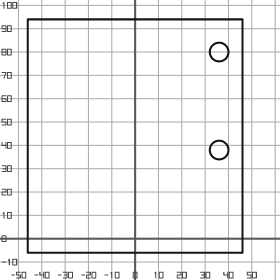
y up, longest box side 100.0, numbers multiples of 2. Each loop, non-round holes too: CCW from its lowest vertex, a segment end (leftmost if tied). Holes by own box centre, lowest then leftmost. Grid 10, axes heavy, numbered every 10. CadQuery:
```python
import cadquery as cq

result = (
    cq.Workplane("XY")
    .moveTo(-46.0, -6.0)
    .lineTo(46.0, -6.0)
    .lineTo(46.0, 94.0)
    .lineTo(-46.0, 94.0)
    .close()
    .moveTo(36.0, 38.0)
    .circle(4.0)
    .moveTo(36.0, 80.0)
    .circle(4.0)
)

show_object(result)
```